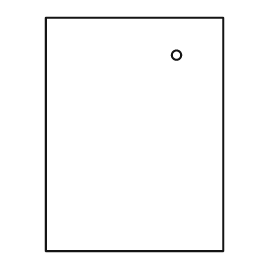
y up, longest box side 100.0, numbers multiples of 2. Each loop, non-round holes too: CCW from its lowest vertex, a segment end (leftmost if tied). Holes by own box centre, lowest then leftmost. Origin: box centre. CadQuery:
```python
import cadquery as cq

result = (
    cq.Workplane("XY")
    .moveTo(-38.0, -50.0)
    .lineTo(38.0, -50.0)
    .lineTo(38.0, 50.0)
    .lineTo(-38.0, 50.0)
    .close()
    .moveTo(18.0, 34.0)
    .circle(2.0)
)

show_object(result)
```